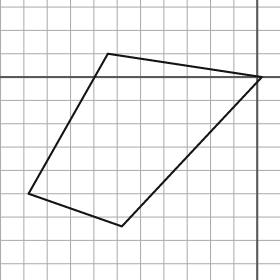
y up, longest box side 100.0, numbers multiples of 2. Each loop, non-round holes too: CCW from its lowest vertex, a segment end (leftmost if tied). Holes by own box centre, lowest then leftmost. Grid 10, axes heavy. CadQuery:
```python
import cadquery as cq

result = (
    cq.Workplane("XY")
    .moveTo(-58.0, -64.0)
    .lineTo(2.0, 0.0)
    .lineTo(-64.0, 10.0)
    .lineTo(-98.0, -50.0)
    .close()
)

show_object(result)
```